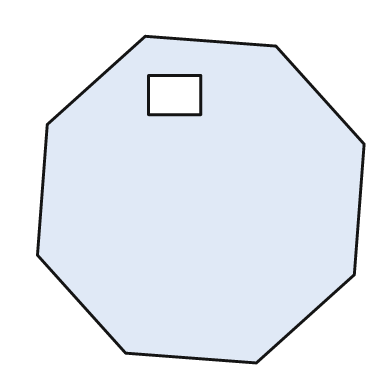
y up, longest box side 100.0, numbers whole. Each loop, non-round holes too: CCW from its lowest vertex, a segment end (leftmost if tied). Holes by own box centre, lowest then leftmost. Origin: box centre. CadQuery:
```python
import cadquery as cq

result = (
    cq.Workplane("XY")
    .moveTo(17.0, -50.0)
    .lineTo(47.0, -23.0)
    .lineTo(50.0, 17.0)
    .lineTo(23.0, 47.0)
    .lineTo(-17.0, 50.0)
    .lineTo(-47.0, 23.0)
    .lineTo(-50.0, -17.0)
    .lineTo(-23.0, -47.0)
    .close()
    .moveTo(-16.0, 26.0)
    .lineTo(0.0, 26.0)
    .lineTo(0.0, 38.0)
    .lineTo(-16.0, 38.0)
    .close()
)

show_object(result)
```